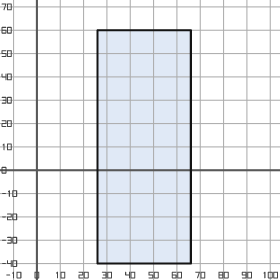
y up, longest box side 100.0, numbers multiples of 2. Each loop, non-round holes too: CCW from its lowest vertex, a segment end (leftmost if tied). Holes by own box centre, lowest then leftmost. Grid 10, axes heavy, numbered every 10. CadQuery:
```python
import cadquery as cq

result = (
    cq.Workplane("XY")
    .moveTo(26.0, -40.0)
    .lineTo(66.0, -40.0)
    .lineTo(66.0, 60.0)
    .lineTo(26.0, 60.0)
    .close()
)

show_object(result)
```